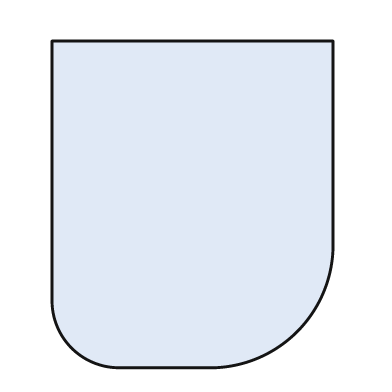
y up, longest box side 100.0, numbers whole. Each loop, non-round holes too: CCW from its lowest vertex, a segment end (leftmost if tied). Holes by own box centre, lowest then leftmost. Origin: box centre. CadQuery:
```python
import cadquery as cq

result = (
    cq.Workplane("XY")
    .moveTo(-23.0, -50.0)
    .lineTo(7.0, -50.0)
    .threePointArc((32.0, -39.0), (43.0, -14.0))
    .lineTo(43.0, 50.0)
    .lineTo(-43.0, 50.0)
    .lineTo(-43.0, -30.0)
    .threePointArc((-37.0, -44.0), (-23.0, -50.0))
    .close()
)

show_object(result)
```